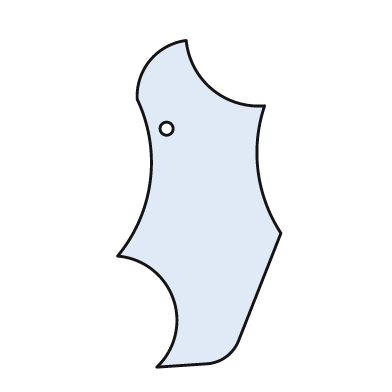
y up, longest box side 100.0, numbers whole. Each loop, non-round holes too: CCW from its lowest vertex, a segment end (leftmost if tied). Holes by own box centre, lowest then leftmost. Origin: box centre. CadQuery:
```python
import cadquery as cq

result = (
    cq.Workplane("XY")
    .moveTo(-13.0, -50.0)
    .lineTo(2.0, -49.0)
    .threePointArc((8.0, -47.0), (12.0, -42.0))
    .lineTo(25.0, -9.0)
    .threePointArc((18.0, 10.0), (20.0, 30.0))
    .threePointArc((4.0, 35.0), (-4.0, 50.0))
    .threePointArc((-15.0, 44.0), (-19.0, 32.0))
    .threePointArc((-15.0, 7.0), (-25.0, -16.0))
    .threePointArc((-8.0, -29.0), (-13.0, -50.0))
    .close()
    .moveTo(-10.0, 23.0)
    .circle(2.0)
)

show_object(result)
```